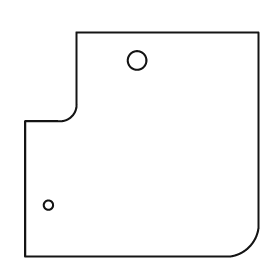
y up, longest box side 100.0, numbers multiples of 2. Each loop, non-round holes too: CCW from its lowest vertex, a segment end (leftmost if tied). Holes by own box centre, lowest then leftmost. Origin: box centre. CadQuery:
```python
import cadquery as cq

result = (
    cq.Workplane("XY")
    .moveTo(-50.0, -48.0)
    .lineTo(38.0, -48.0)
    .threePointArc((46.0, -44.0), (50.0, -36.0))
    .lineTo(50.0, 48.0)
    .lineTo(-28.0, 48.0)
    .lineTo(-28.0, 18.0)
    .threePointArc((-30.0, 12.0), (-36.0, 10.0))
    .lineTo(-50.0, 10.0)
    .close()
    .moveTo(-40.0, -26.0)
    .circle(2.0)
    .moveTo(-2.0, 36.0)
    .circle(4.0)
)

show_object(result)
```